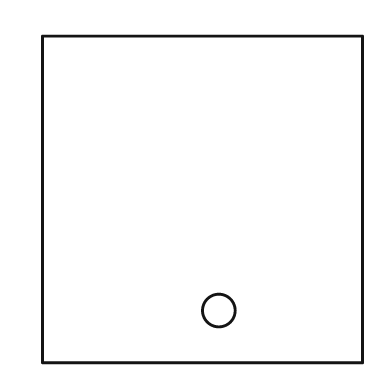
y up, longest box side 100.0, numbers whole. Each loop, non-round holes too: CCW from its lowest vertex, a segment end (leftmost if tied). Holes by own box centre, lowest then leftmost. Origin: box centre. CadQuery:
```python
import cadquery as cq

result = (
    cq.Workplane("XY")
    .moveTo(-49.0, -50.0)
    .lineTo(49.0, -50.0)
    .lineTo(49.0, 50.0)
    .lineTo(-49.0, 50.0)
    .close()
    .moveTo(5.0, -34.0)
    .circle(5.0)
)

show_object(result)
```